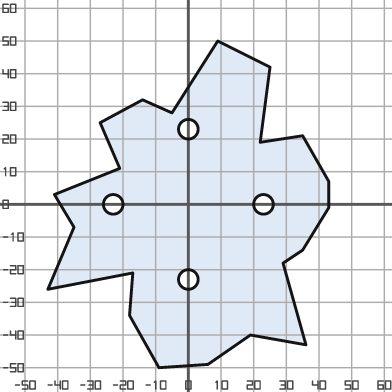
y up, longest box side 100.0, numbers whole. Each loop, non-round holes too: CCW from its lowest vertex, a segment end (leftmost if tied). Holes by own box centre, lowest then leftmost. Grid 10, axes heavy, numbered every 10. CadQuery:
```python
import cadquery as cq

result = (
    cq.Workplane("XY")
    .moveTo(-9.0, -50.0)
    .lineTo(6.0, -49.0)
    .lineTo(19.0, -40.0)
    .lineTo(36.0, -43.0)
    .lineTo(29.0, -18.0)
    .lineTo(35.0, -14.0)
    .lineTo(43.0, -1.0)
    .lineTo(43.0, 7.0)
    .lineTo(35.0, 21.0)
    .lineTo(22.0, 19.0)
    .lineTo(25.0, 42.0)
    .lineTo(9.0, 50.0)
    .lineTo(-5.0, 28.0)
    .lineTo(-14.0, 32.0)
    .lineTo(-27.0, 25.0)
    .lineTo(-21.0, 11.0)
    .lineTo(-41.0, 3.0)
    .lineTo(-35.0, -7.0)
    .lineTo(-43.0, -26.0)
    .lineTo(-17.0, -21.0)
    .lineTo(-18.0, -34.0)
    .close()
    .moveTo(0.0, -23.0)
    .circle(3.0)
    .moveTo(-23.0, 0.0)
    .circle(3.0)
    .moveTo(23.0, 0.0)
    .circle(3.0)
    .moveTo(0.0, 23.0)
    .circle(3.0)
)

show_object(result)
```